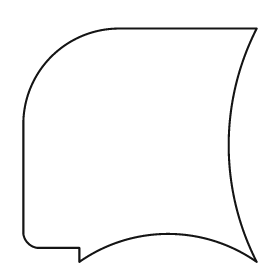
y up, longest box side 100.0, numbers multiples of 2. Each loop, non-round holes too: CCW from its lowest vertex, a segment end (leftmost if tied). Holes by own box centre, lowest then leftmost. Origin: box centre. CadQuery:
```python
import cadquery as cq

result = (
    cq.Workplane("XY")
    .moveTo(-26.0, -50.0)
    .threePointArc((12.0, -38.0), (50.0, -50.0))
    .threePointArc((38.0, 0.0), (50.0, 50.0))
    .lineTo(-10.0, 50.0)
    .threePointArc((-38.0, 38.0), (-50.0, 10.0))
    .lineTo(-50.0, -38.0)
    .threePointArc((-48.0, -42.0), (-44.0, -44.0))
    .lineTo(-26.0, -44.0)
    .close()
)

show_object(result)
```